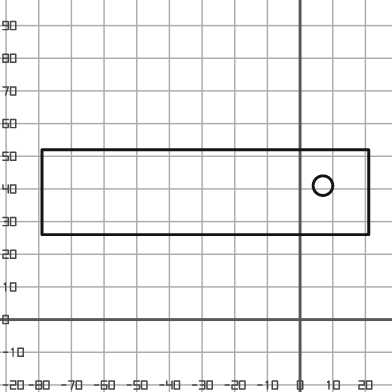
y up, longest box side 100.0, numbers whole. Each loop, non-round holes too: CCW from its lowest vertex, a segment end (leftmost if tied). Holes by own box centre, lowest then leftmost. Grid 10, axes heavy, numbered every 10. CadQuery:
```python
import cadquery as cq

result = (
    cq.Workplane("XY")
    .moveTo(-79.0, 26.0)
    .lineTo(21.0, 26.0)
    .lineTo(21.0, 52.0)
    .lineTo(-79.0, 52.0)
    .close()
    .moveTo(7.0, 41.0)
    .circle(3.0)
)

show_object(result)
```